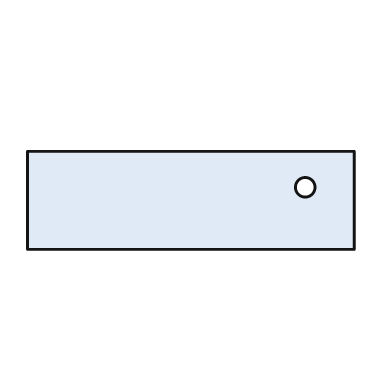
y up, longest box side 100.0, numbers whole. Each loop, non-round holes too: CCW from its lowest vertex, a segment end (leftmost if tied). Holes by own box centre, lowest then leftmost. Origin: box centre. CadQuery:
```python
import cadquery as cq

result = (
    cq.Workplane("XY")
    .moveTo(-50.0, -15.0)
    .lineTo(50.0, -15.0)
    .lineTo(50.0, 15.0)
    .lineTo(-50.0, 15.0)
    .close()
    .moveTo(35.0, 4.0)
    .circle(3.0)
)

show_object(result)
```